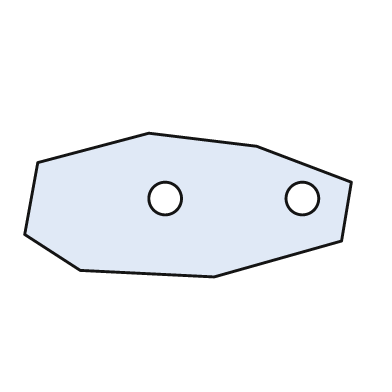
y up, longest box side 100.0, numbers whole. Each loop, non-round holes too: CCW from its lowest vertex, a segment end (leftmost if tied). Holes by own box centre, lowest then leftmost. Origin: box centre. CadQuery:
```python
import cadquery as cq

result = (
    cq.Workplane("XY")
    .moveTo(8.0, -22.0)
    .lineTo(47.0, -11.0)
    .lineTo(50.0, 7.0)
    .lineTo(21.0, 18.0)
    .lineTo(-12.0, 22.0)
    .lineTo(-46.0, 13.0)
    .lineTo(-50.0, -9.0)
    .lineTo(-33.0, -20.0)
    .close()
    .moveTo(-7.0, 2.0)
    .circle(5.0)
    .moveTo(35.0, 2.0)
    .circle(5.0)
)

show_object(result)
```